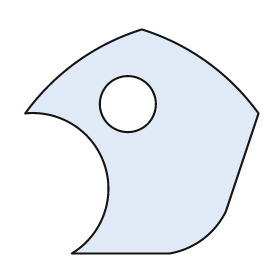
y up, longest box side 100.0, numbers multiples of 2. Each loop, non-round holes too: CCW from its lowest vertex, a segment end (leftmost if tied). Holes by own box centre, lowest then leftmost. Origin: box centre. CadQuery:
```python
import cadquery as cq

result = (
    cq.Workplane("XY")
    .moveTo(-30.0, -48.0)
    .lineTo(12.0, -48.0)
    .threePointArc((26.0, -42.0), (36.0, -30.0))
    .lineTo(50.0, 12.0)
    .threePointArc((28.0, 34.0), (0.0, 48.0))
    .threePointArc((-28.0, 34.0), (-50.0, 12.0))
    .threePointArc((-16.0, -10.0), (-30.0, -48.0))
    .close()
    .moveTo(-6.0, 16.0)
    .circle(12.0)
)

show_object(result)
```